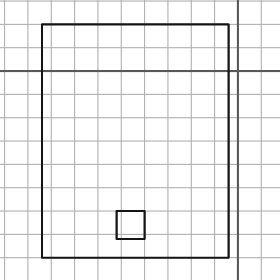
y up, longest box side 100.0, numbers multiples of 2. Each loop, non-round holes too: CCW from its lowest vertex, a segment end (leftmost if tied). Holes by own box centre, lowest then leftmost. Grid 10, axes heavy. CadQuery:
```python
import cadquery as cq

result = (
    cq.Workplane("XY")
    .moveTo(-84.0, -80.0)
    .lineTo(-4.0, -80.0)
    .lineTo(-4.0, 20.0)
    .lineTo(-84.0, 20.0)
    .close()
    .moveTo(-52.0, -72.0)
    .lineTo(-40.0, -72.0)
    .lineTo(-40.0, -60.0)
    .lineTo(-52.0, -60.0)
    .close()
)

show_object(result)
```